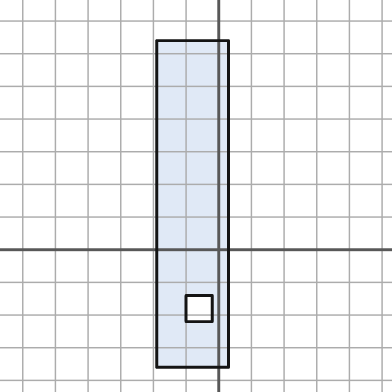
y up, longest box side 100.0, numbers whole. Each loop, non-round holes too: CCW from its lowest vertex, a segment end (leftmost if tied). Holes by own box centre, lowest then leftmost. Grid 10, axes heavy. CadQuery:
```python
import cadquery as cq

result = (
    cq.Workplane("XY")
    .moveTo(-19.0, -36.0)
    .lineTo(3.0, -36.0)
    .lineTo(3.0, 64.0)
    .lineTo(-19.0, 64.0)
    .close()
    .moveTo(-10.0, -22.0)
    .lineTo(-2.0, -22.0)
    .lineTo(-2.0, -14.0)
    .lineTo(-10.0, -14.0)
    .close()
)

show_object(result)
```